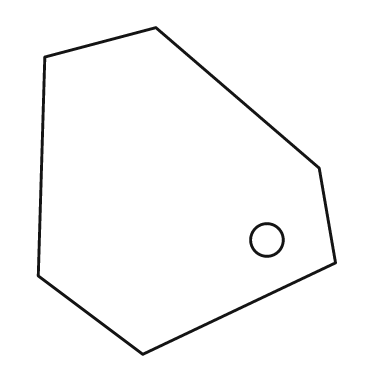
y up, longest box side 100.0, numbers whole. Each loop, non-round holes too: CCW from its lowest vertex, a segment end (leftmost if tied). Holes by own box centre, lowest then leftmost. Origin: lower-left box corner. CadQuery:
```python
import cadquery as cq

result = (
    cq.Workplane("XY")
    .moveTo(32.0, 0.0)
    .lineTo(91.0, 28.0)
    .lineTo(86.0, 57.0)
    .lineTo(36.0, 100.0)
    .lineTo(2.0, 91.0)
    .lineTo(0.0, 24.0)
    .close()
    .moveTo(70.0, 35.0)
    .circle(5.0)
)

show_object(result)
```